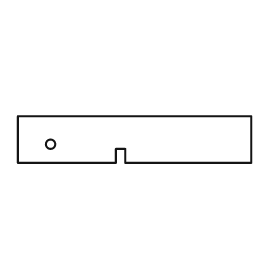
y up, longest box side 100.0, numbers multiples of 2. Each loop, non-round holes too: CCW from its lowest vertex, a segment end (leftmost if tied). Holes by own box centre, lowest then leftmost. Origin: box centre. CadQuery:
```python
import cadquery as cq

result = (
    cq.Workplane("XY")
    .moveTo(-50.0, -10.0)
    .lineTo(-8.0, -10.0)
    .lineTo(-8.0, -4.0)
    .lineTo(-4.0, -4.0)
    .lineTo(-4.0, -10.0)
    .lineTo(50.0, -10.0)
    .lineTo(50.0, 10.0)
    .lineTo(-50.0, 10.0)
    .close()
    .moveTo(-36.0, -2.0)
    .circle(2.0)
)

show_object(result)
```